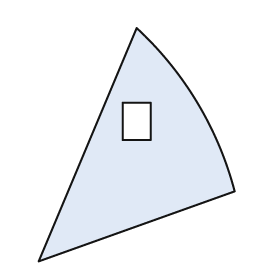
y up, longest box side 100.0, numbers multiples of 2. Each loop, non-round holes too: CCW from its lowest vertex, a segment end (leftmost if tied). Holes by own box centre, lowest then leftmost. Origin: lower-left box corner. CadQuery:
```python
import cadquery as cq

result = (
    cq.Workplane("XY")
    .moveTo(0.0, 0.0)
    .lineTo(84.0, 30.0)
    .threePointArc((68.0, 68.0), (42.0, 100.0))
    .close()
    .moveTo(36.0, 52.0)
    .lineTo(48.0, 52.0)
    .lineTo(48.0, 68.0)
    .lineTo(36.0, 68.0)
    .close()
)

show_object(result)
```